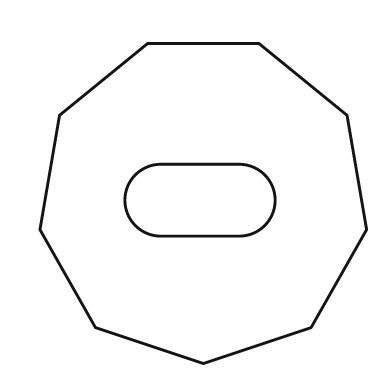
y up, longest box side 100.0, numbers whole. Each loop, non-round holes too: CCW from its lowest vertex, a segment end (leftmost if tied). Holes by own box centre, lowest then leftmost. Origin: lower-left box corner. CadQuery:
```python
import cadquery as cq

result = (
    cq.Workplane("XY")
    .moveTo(50.0, 0.0)
    .lineTo(83.0, 11.0)
    .lineTo(100.0, 41.0)
    .lineTo(94.0, 76.0)
    .lineTo(67.0, 98.0)
    .lineTo(33.0, 98.0)
    .lineTo(6.0, 76.0)
    .lineTo(0.0, 41.0)
    .lineTo(17.0, 11.0)
    .close()
    .moveTo(37.0, 39.0)
    .lineTo(61.0, 39.0)
    .threePointArc((72.0, 50.0), (61.0, 61.0))
    .lineTo(37.0, 61.0)
    .threePointArc((26.0, 50.0), (37.0, 39.0))
    .close()
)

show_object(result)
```